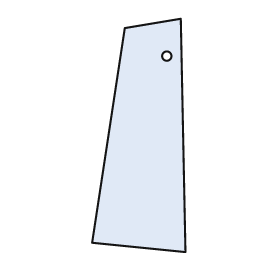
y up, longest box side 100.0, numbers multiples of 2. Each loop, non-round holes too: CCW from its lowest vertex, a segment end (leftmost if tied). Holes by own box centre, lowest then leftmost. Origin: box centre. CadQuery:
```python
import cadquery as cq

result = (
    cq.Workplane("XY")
    .moveTo(20.0, -50.0)
    .lineTo(18.0, 50.0)
    .lineTo(-6.0, 46.0)
    .lineTo(-20.0, -46.0)
    .close()
    .moveTo(12.0, 34.0)
    .circle(2.0)
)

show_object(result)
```